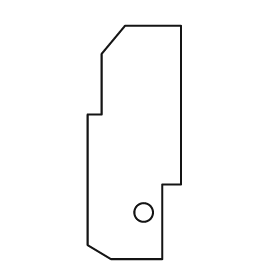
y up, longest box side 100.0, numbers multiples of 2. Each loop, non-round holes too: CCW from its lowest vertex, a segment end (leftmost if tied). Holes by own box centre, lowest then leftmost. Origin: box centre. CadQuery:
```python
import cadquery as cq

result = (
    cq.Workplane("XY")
    .moveTo(-10.0, -50.0)
    .lineTo(12.0, -50.0)
    .lineTo(12.0, -18.0)
    .lineTo(20.0, -18.0)
    .lineTo(20.0, 50.0)
    .lineTo(-4.0, 50.0)
    .lineTo(-14.0, 38.0)
    .lineTo(-14.0, 12.0)
    .lineTo(-20.0, 12.0)
    .lineTo(-20.0, -44.0)
    .close()
    .moveTo(4.0, -30.0)
    .circle(4.0)
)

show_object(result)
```